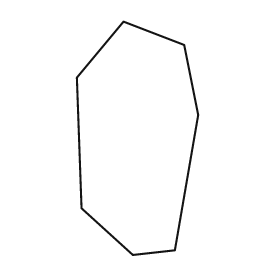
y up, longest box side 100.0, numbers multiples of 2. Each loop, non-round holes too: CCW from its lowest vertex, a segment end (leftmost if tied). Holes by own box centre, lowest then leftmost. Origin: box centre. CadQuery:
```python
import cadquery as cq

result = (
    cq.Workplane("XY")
    .moveTo(-2.0, -50.0)
    .lineTo(16.0, -48.0)
    .lineTo(26.0, 10.0)
    .lineTo(20.0, 40.0)
    .lineTo(-6.0, 50.0)
    .lineTo(-26.0, 26.0)
    .lineTo(-24.0, -30.0)
    .close()
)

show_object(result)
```